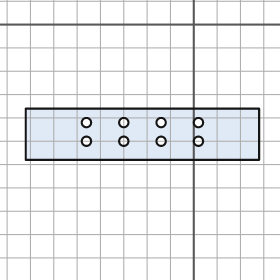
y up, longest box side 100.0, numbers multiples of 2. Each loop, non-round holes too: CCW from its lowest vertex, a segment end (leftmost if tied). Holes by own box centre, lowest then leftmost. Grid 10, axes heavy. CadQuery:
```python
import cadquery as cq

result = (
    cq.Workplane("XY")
    .moveTo(-72.0, -58.0)
    .lineTo(28.0, -58.0)
    .lineTo(28.0, -36.0)
    .lineTo(-72.0, -36.0)
    .close()
    .moveTo(-46.0, -50.0)
    .circle(2.0)
    .moveTo(-30.0, -50.0)
    .circle(2.0)
    .moveTo(-14.0, -50.0)
    .circle(2.0)
    .moveTo(2.0, -50.0)
    .circle(2.0)
    .moveTo(-46.0, -42.0)
    .circle(2.0)
    .moveTo(-30.0, -42.0)
    .circle(2.0)
    .moveTo(-14.0, -42.0)
    .circle(2.0)
    .moveTo(2.0, -42.0)
    .circle(2.0)
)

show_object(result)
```